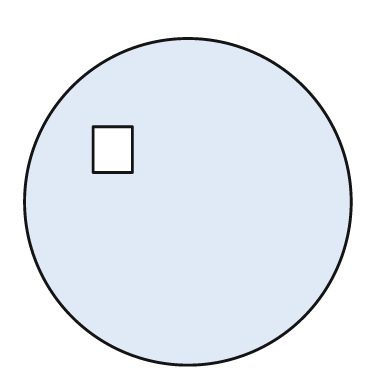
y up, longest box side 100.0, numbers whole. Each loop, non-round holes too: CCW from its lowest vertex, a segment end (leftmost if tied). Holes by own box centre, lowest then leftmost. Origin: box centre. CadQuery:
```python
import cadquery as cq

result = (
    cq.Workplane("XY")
    .moveTo(0.0, 0.0)
    .circle(50.0)
    .moveTo(-29.0, 9.0)
    .lineTo(-17.0, 9.0)
    .lineTo(-17.0, 23.0)
    .lineTo(-29.0, 23.0)
    .close()
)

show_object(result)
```